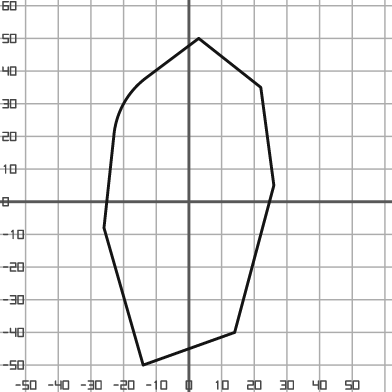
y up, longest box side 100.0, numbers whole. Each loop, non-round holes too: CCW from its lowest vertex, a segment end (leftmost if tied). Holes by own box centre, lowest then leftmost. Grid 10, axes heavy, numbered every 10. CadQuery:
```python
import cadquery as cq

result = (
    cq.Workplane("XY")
    .moveTo(-14.0, -50.0)
    .lineTo(14.0, -40.0)
    .lineTo(26.0, 5.0)
    .lineTo(22.0, 35.0)
    .lineTo(3.0, 50.0)
    .lineTo(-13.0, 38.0)
    .threePointArc((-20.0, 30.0), (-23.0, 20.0))
    .lineTo(-26.0, -8.0)
    .close()
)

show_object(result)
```